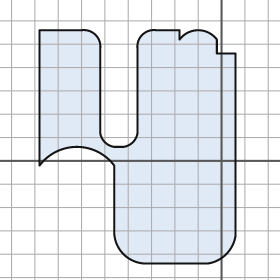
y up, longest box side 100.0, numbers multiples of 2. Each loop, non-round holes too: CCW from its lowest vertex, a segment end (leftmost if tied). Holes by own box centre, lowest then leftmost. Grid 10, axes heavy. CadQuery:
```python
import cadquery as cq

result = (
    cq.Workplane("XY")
    .moveTo(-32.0, -44.0)
    .lineTo(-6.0, -44.0)
    .threePointArc((2.0, -40.0), (6.0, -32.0))
    .lineTo(6.0, 46.0)
    .lineTo(-2.0, 46.0)
    .lineTo(-2.0, 52.0)
    .threePointArc((-10.0, 56.0), (-18.0, 52.0))
    .lineTo(-18.0, 56.0)
    .lineTo(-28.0, 56.0)
    .threePointArc((-34.0, 54.0), (-36.0, 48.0))
    .lineTo(-36.0, 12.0)
    .threePointArc((-38.0, 8.0), (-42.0, 6.0))
    .lineTo(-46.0, 6.0)
    .threePointArc((-50.0, 8.0), (-52.0, 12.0))
    .lineTo(-52.0, 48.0)
    .threePointArc((-54.0, 54.0), (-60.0, 56.0))
    .lineTo(-78.0, 56.0)
    .lineTo(-78.0, -2.0)
    .threePointArc((-62.0, 6.0), (-46.0, -2.0))
    .lineTo(-46.0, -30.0)
    .threePointArc((-42.0, -40.0), (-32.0, -44.0))
    .close()
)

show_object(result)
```